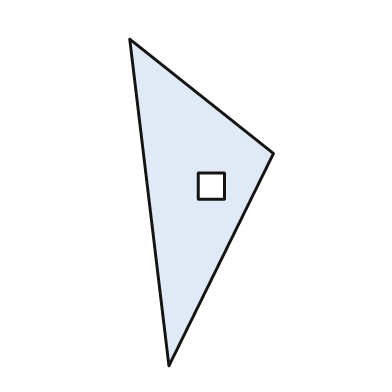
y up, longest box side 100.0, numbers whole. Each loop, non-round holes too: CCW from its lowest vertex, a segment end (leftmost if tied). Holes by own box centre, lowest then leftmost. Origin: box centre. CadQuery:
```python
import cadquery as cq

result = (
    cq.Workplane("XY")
    .moveTo(-10.0, -50.0)
    .lineTo(22.0, 15.0)
    .lineTo(-22.0, 50.0)
    .close()
    .moveTo(-1.0, 1.0)
    .lineTo(7.0, 1.0)
    .lineTo(7.0, 9.0)
    .lineTo(-1.0, 9.0)
    .close()
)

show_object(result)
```